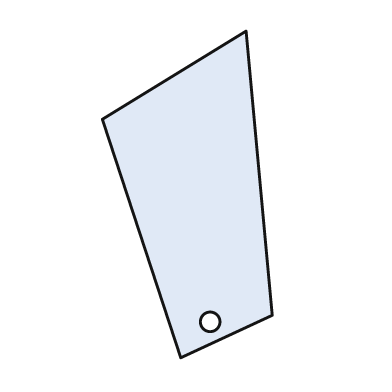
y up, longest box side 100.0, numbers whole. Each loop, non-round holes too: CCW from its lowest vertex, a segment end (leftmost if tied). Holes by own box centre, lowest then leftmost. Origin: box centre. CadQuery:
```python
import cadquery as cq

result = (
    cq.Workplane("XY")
    .moveTo(-2.0, -50.0)
    .lineTo(26.0, -37.0)
    .lineTo(18.0, 50.0)
    .lineTo(-26.0, 23.0)
    .close()
    .moveTo(7.0, -39.0)
    .circle(3.0)
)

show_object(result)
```